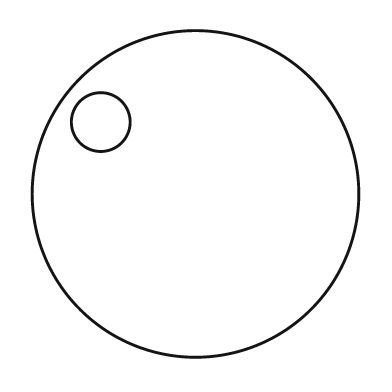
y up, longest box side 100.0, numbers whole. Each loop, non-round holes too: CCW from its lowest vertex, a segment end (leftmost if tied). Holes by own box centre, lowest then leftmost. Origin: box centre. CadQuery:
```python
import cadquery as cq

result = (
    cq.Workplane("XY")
    .moveTo(0.0, 0.0)
    .circle(50.0)
    .moveTo(-29.0, 22.0)
    .circle(9.0)
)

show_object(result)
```